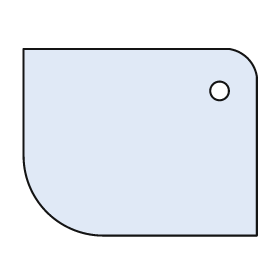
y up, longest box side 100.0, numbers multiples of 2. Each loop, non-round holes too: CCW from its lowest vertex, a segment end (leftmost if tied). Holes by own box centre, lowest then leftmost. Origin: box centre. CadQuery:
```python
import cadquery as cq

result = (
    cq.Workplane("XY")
    .moveTo(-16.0, -40.0)
    .lineTo(50.0, -40.0)
    .lineTo(50.0, 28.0)
    .threePointArc((46.0, 36.0), (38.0, 40.0))
    .lineTo(-50.0, 40.0)
    .lineTo(-50.0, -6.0)
    .threePointArc((-40.0, -30.0), (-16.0, -40.0))
    .close()
    .moveTo(34.0, 22.0)
    .circle(4.0)
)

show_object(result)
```